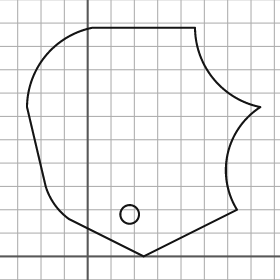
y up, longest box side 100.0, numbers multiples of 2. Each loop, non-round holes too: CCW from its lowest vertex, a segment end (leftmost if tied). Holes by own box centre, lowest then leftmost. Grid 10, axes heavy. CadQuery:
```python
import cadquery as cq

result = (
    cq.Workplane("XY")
    .moveTo(24.0, 0.0)
    .lineTo(64.0, 20.0)
    .threePointArc((60.0, 44.0), (74.0, 64.0))
    .threePointArc((54.0, 76.0), (46.0, 98.0))
    .lineTo(2.0, 98.0)
    .threePointArc((-18.0, 86.0), (-26.0, 64.0))
    .lineTo(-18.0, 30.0)
    .threePointArc((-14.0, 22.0), (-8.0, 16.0))
    .close()
    .moveTo(18.0, 18.0)
    .circle(4.0)
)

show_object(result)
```